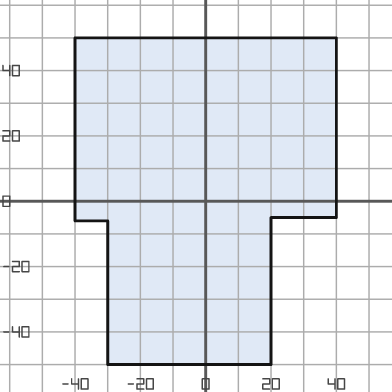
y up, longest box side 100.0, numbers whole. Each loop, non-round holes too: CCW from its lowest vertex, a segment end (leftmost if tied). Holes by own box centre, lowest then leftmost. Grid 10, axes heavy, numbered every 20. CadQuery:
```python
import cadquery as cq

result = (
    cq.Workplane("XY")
    .moveTo(-30.0, -50.0)
    .lineTo(20.0, -50.0)
    .lineTo(20.0, -5.0)
    .lineTo(40.0, -5.0)
    .lineTo(40.0, 50.0)
    .lineTo(-40.0, 50.0)
    .lineTo(-40.0, -6.0)
    .lineTo(-30.0, -6.0)
    .close()
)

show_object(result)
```